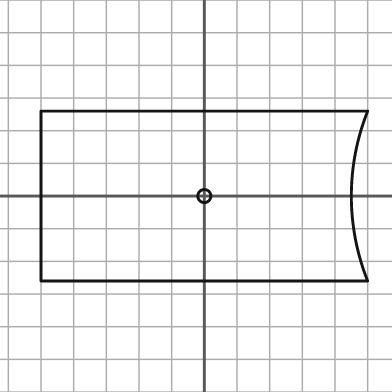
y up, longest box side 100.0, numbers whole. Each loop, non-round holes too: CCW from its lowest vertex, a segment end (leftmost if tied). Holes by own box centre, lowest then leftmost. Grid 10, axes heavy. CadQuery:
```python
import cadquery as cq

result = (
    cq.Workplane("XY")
    .moveTo(-50.0, -26.0)
    .lineTo(50.0, -26.0)
    .threePointArc((45.0, 0.0), (50.0, 26.0))
    .lineTo(-50.0, 26.0)
    .close()
    .moveTo(0.0, 0.0)
    .circle(2.0)
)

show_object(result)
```